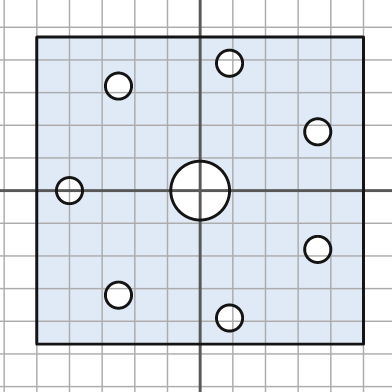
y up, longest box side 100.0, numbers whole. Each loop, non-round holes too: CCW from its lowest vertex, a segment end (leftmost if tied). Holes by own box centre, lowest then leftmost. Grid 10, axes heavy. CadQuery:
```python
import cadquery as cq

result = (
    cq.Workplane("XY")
    .moveTo(-50.0, -47.0)
    .lineTo(50.0, -47.0)
    .lineTo(50.0, 47.0)
    .lineTo(-50.0, 47.0)
    .close()
    .moveTo(9.0, -39.0)
    .circle(4.0)
    .moveTo(-25.0, -32.0)
    .circle(4.0)
    .moveTo(36.0, -18.0)
    .circle(4.0)
    .moveTo(-40.0, 0.0)
    .circle(4.0)
    .moveTo(0.0, 0.0)
    .circle(9.0)
    .moveTo(36.0, 18.0)
    .circle(4.0)
    .moveTo(-25.0, 32.0)
    .circle(4.0)
    .moveTo(9.0, 39.0)
    .circle(4.0)
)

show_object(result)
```